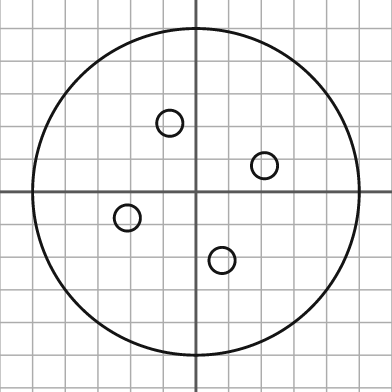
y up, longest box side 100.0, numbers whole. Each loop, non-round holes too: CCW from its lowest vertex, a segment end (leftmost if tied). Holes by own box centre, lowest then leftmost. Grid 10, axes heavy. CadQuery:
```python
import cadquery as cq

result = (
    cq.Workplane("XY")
    .moveTo(0.0, 0.0)
    .circle(50.0)
    .moveTo(8.0, -21.0)
    .circle(4.0)
    .moveTo(-21.0, -8.0)
    .circle(4.0)
    .moveTo(21.0, 8.0)
    .circle(4.0)
    .moveTo(-8.0, 21.0)
    .circle(4.0)
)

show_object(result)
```